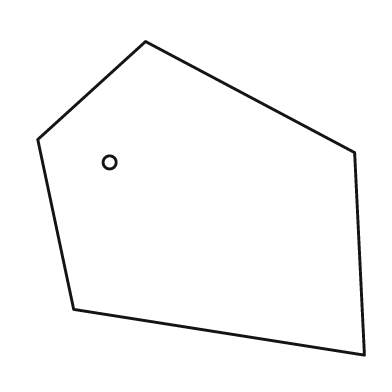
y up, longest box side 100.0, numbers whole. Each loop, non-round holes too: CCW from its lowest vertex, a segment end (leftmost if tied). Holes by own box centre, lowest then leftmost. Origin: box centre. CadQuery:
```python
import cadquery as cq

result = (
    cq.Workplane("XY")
    .moveTo(50.0, -48.0)
    .lineTo(47.0, 14.0)
    .lineTo(-17.0, 48.0)
    .lineTo(-50.0, 18.0)
    .lineTo(-39.0, -34.0)
    .close()
    .moveTo(-28.0, 11.0)
    .circle(2.0)
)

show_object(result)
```